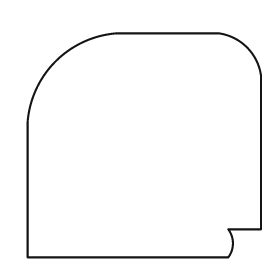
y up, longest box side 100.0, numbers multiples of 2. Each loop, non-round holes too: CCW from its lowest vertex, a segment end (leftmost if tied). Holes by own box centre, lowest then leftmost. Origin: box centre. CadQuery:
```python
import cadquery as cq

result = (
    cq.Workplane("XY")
    .moveTo(-50.0, -48.0)
    .lineTo(36.0, -48.0)
    .threePointArc((38.0, -42.0), (36.0, -36.0))
    .lineTo(50.0, -36.0)
    .lineTo(50.0, 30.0)
    .threePointArc((44.0, 42.0), (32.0, 48.0))
    .lineTo(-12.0, 48.0)
    .threePointArc((-38.0, 36.0), (-50.0, 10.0))
    .close()
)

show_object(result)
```